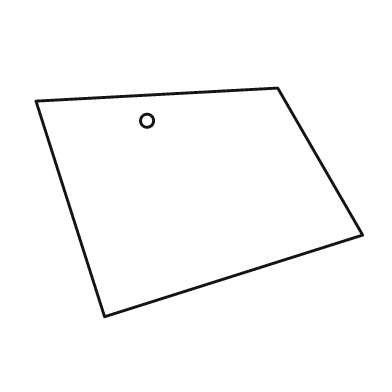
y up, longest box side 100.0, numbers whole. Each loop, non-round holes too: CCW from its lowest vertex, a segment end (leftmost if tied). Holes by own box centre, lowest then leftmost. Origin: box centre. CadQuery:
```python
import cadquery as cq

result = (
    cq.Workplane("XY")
    .moveTo(-29.0, -35.0)
    .lineTo(50.0, -10.0)
    .lineTo(24.0, 35.0)
    .lineTo(-50.0, 31.0)
    .close()
    .moveTo(-16.0, 25.0)
    .circle(2.0)
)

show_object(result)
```